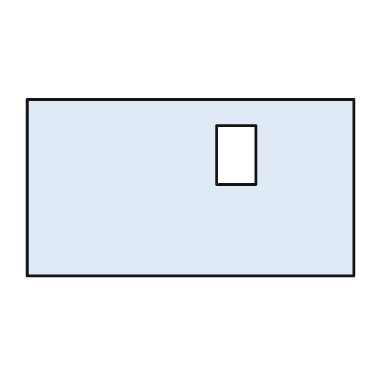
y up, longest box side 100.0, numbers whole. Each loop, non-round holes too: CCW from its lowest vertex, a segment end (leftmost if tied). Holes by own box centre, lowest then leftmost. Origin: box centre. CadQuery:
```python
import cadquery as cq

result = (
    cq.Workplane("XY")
    .moveTo(-50.0, -27.0)
    .lineTo(50.0, -27.0)
    .lineTo(50.0, 27.0)
    .lineTo(-50.0, 27.0)
    .close()
    .moveTo(8.0, 1.0)
    .lineTo(20.0, 1.0)
    .lineTo(20.0, 19.0)
    .lineTo(8.0, 19.0)
    .close()
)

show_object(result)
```